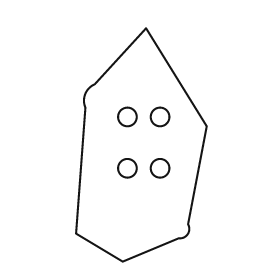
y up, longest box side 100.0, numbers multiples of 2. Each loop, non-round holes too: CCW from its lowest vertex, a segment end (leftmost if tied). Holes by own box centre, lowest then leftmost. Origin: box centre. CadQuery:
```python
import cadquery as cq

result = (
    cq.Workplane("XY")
    .moveTo(-8.0, -50.0)
    .lineTo(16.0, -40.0)
    .threePointArc((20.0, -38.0), (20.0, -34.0))
    .lineTo(28.0, 8.0)
    .lineTo(2.0, 50.0)
    .lineTo(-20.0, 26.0)
    .threePointArc((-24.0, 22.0), (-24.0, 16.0))
    .lineTo(-28.0, -38.0)
    .close()
    .moveTo(-6.0, -10.0)
    .circle(4.0)
    .moveTo(8.0, -10.0)
    .circle(4.0)
    .moveTo(-6.0, 12.0)
    .circle(4.0)
    .moveTo(8.0, 12.0)
    .circle(4.0)
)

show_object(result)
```